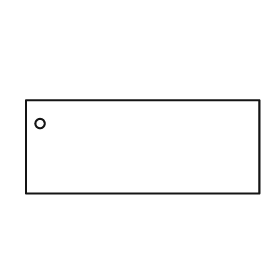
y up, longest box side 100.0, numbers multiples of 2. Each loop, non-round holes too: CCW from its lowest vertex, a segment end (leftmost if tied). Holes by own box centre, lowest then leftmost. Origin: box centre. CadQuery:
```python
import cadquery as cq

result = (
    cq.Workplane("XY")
    .moveTo(-50.0, -20.0)
    .lineTo(50.0, -20.0)
    .lineTo(50.0, 20.0)
    .lineTo(-50.0, 20.0)
    .close()
    .moveTo(-44.0, 10.0)
    .circle(2.0)
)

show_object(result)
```